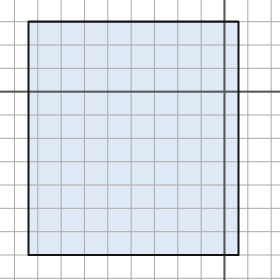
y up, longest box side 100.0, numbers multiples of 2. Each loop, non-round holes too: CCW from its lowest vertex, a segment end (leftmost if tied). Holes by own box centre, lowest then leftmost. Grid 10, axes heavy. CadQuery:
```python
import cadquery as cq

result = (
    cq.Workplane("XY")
    .moveTo(-84.0, -70.0)
    .lineTo(6.0, -70.0)
    .lineTo(6.0, 30.0)
    .lineTo(-84.0, 30.0)
    .close()
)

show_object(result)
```